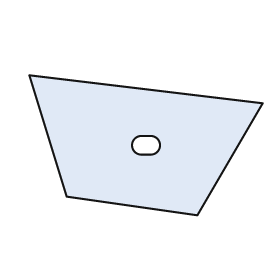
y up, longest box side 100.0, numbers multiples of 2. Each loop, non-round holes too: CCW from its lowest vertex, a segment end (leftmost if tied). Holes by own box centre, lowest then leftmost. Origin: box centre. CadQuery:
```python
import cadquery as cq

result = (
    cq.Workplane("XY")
    .moveTo(22.0, -30.0)
    .lineTo(50.0, 18.0)
    .lineTo(-50.0, 30.0)
    .lineTo(-34.0, -22.0)
    .close()
    .moveTo(-2.0, -4.0)
    .lineTo(2.0, -4.0)
    .threePointArc((6.0, 0.0), (2.0, 4.0))
    .lineTo(-2.0, 4.0)
    .threePointArc((-6.0, 0.0), (-2.0, -4.0))
    .close()
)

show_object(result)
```